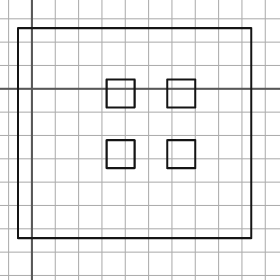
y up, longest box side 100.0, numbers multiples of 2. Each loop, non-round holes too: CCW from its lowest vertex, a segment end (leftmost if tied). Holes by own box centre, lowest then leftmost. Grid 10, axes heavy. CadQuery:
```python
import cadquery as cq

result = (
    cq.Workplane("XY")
    .moveTo(-6.0, -64.0)
    .lineTo(94.0, -64.0)
    .lineTo(94.0, 26.0)
    .lineTo(-6.0, 26.0)
    .close()
    .moveTo(32.0, -34.0)
    .lineTo(44.0, -34.0)
    .lineTo(44.0, -22.0)
    .lineTo(32.0, -22.0)
    .close()
    .moveTo(58.0, -34.0)
    .lineTo(70.0, -34.0)
    .lineTo(70.0, -22.0)
    .lineTo(58.0, -22.0)
    .close()
    .moveTo(32.0, -8.0)
    .lineTo(44.0, -8.0)
    .lineTo(44.0, 4.0)
    .lineTo(32.0, 4.0)
    .close()
    .moveTo(58.0, -8.0)
    .lineTo(70.0, -8.0)
    .lineTo(70.0, 4.0)
    .lineTo(58.0, 4.0)
    .close()
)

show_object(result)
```